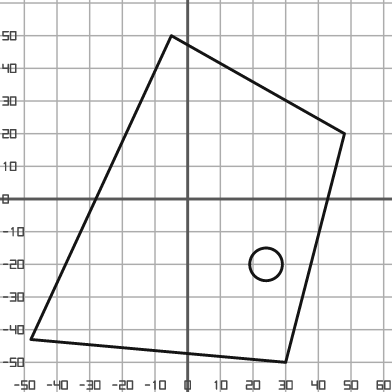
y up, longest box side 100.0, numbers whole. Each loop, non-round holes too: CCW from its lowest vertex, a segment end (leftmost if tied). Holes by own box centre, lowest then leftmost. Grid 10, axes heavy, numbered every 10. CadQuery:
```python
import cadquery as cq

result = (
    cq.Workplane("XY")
    .moveTo(30.0, -50.0)
    .lineTo(48.0, 20.0)
    .lineTo(-5.0, 50.0)
    .lineTo(-48.0, -43.0)
    .close()
    .moveTo(24.0, -20.0)
    .circle(5.0)
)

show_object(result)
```